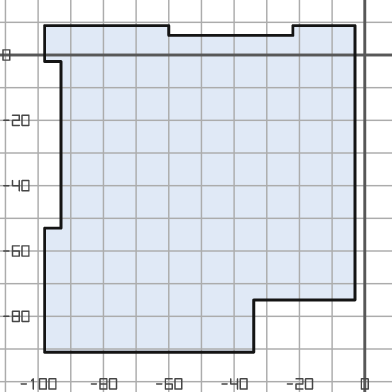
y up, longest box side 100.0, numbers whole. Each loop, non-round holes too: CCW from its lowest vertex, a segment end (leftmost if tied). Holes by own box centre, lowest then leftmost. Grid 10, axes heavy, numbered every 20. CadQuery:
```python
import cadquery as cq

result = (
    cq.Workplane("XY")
    .moveTo(-98.0, -91.0)
    .lineTo(-34.0, -91.0)
    .lineTo(-34.0, -75.0)
    .lineTo(-3.0, -75.0)
    .lineTo(-3.0, 9.0)
    .lineTo(-22.0, 9.0)
    .lineTo(-22.0, 6.0)
    .lineTo(-60.0, 6.0)
    .lineTo(-60.0, 9.0)
    .lineTo(-98.0, 9.0)
    .lineTo(-98.0, -2.0)
    .lineTo(-93.0, -2.0)
    .lineTo(-93.0, -53.0)
    .lineTo(-98.0, -53.0)
    .close()
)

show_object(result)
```